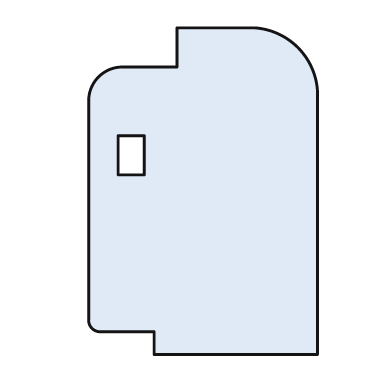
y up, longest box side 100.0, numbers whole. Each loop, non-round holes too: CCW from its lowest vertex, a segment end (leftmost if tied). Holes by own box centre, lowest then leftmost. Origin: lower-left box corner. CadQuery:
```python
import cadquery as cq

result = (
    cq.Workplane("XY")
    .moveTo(20.0, 0.0)
    .lineTo(70.0, 0.0)
    .lineTo(70.0, 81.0)
    .threePointArc((64.0, 94.0), (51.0, 100.0))
    .lineTo(27.0, 100.0)
    .lineTo(27.0, 88.0)
    .lineTo(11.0, 88.0)
    .threePointArc((3.0, 85.0), (0.0, 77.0))
    .lineTo(0.0, 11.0)
    .threePointArc((1.0, 8.0), (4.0, 7.0))
    .lineTo(20.0, 7.0)
    .close()
    .moveTo(9.0, 55.0)
    .lineTo(17.0, 55.0)
    .lineTo(17.0, 67.0)
    .lineTo(9.0, 67.0)
    .close()
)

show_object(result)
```